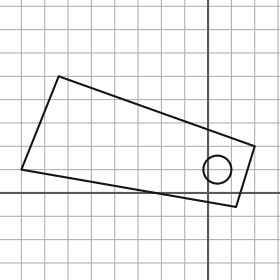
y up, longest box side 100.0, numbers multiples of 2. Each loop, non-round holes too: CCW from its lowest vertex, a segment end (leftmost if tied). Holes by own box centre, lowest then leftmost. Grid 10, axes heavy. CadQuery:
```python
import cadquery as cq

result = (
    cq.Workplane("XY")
    .moveTo(12.0, -6.0)
    .lineTo(20.0, 20.0)
    .lineTo(-64.0, 50.0)
    .lineTo(-80.0, 10.0)
    .close()
    .moveTo(4.0, 10.0)
    .circle(6.0)
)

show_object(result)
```